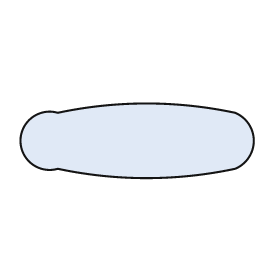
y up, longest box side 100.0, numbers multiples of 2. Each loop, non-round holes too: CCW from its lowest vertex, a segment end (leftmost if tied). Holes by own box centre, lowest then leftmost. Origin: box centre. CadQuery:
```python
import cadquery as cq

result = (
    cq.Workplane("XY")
    .moveTo(-34.0, -12.0)
    .threePointArc((4.0, -16.0), (42.0, -12.0))
    .threePointArc((50.0, 0.0), (42.0, 12.0))
    .threePointArc((4.0, 16.0), (-34.0, 12.0))
    .threePointArc((-50.0, 0.0), (-34.0, -12.0))
    .close()
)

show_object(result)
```